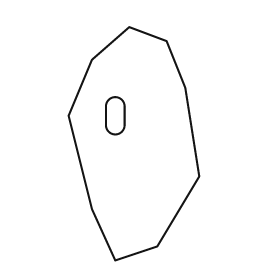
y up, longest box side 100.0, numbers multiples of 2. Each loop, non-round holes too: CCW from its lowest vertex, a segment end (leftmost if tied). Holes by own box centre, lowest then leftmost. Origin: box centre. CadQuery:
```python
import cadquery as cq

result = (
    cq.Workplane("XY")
    .moveTo(-8.0, -50.0)
    .lineTo(10.0, -44.0)
    .lineTo(28.0, -14.0)
    .lineTo(22.0, 24.0)
    .lineTo(14.0, 44.0)
    .lineTo(-2.0, 50.0)
    .lineTo(-18.0, 36.0)
    .lineTo(-28.0, 12.0)
    .lineTo(-18.0, -28.0)
    .close()
    .moveTo(-12.0, 8.0)
    .threePointArc((-8.0, 4.0), (-4.0, 8.0))
    .lineTo(-4.0, 16.0)
    .threePointArc((-8.0, 20.0), (-12.0, 16.0))
    .close()
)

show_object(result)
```